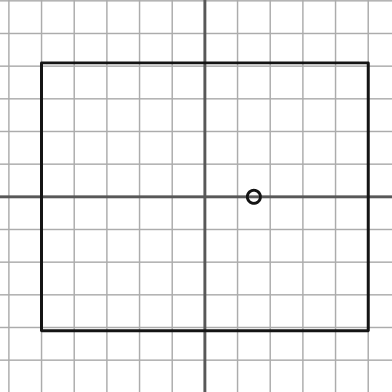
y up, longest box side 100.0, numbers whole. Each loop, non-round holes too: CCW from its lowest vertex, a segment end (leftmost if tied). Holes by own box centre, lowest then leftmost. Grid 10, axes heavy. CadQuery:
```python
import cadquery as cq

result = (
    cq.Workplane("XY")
    .moveTo(-50.0, -41.0)
    .lineTo(50.0, -41.0)
    .lineTo(50.0, 41.0)
    .lineTo(-50.0, 41.0)
    .close()
    .moveTo(15.0, 0.0)
    .circle(2.0)
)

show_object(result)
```